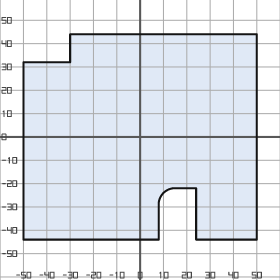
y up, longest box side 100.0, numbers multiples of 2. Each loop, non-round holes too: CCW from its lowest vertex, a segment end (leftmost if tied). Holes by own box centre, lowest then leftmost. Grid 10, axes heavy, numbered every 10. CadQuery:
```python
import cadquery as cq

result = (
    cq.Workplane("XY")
    .moveTo(-50.0, -44.0)
    .lineTo(8.0, -44.0)
    .lineTo(8.0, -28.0)
    .threePointArc((10.0, -24.0), (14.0, -22.0))
    .lineTo(24.0, -22.0)
    .lineTo(24.0, -44.0)
    .lineTo(50.0, -44.0)
    .lineTo(50.0, 44.0)
    .lineTo(-30.0, 44.0)
    .lineTo(-30.0, 32.0)
    .lineTo(-50.0, 32.0)
    .close()
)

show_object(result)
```